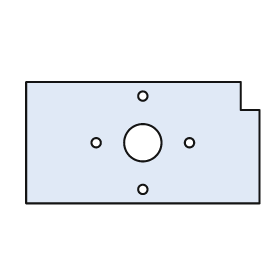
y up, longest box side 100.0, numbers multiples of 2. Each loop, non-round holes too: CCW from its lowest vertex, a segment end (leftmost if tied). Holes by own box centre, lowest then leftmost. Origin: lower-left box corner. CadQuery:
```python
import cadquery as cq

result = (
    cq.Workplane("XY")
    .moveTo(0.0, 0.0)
    .lineTo(100.0, 0.0)
    .lineTo(100.0, 40.0)
    .lineTo(92.0, 40.0)
    .lineTo(92.0, 52.0)
    .lineTo(0.0, 52.0)
    .close()
    .moveTo(50.0, 6.0)
    .circle(2.0)
    .moveTo(30.0, 26.0)
    .circle(2.0)
    .moveTo(50.0, 26.0)
    .circle(8.0)
    .moveTo(70.0, 26.0)
    .circle(2.0)
    .moveTo(50.0, 46.0)
    .circle(2.0)
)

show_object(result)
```